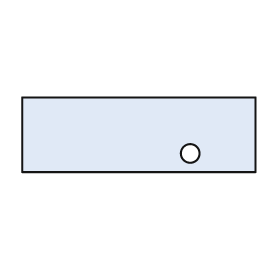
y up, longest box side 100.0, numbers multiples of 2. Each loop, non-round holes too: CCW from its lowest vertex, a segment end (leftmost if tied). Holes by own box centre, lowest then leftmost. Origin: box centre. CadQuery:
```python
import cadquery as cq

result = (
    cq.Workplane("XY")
    .moveTo(-50.0, -16.0)
    .lineTo(50.0, -16.0)
    .lineTo(50.0, 16.0)
    .lineTo(-50.0, 16.0)
    .close()
    .moveTo(22.0, -8.0)
    .circle(4.0)
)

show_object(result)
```